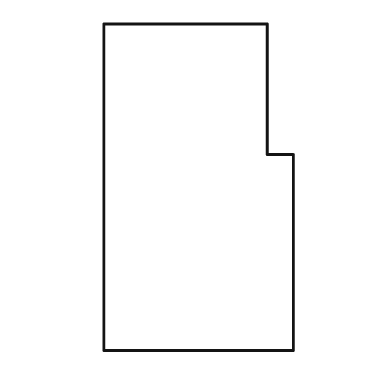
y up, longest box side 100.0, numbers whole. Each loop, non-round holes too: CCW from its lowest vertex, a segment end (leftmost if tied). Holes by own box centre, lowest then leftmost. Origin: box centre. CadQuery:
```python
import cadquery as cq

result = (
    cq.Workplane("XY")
    .moveTo(-29.0, -50.0)
    .lineTo(29.0, -50.0)
    .lineTo(29.0, 10.0)
    .lineTo(21.0, 10.0)
    .lineTo(21.0, 50.0)
    .lineTo(-29.0, 50.0)
    .close()
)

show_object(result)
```